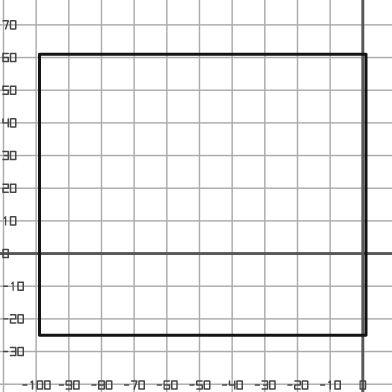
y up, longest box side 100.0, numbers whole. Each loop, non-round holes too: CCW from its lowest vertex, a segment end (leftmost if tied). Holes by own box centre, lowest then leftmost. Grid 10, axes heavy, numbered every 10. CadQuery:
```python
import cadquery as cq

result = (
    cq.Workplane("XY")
    .moveTo(-99.0, -25.0)
    .lineTo(1.0, -25.0)
    .lineTo(1.0, 61.0)
    .lineTo(-99.0, 61.0)
    .close()
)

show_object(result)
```